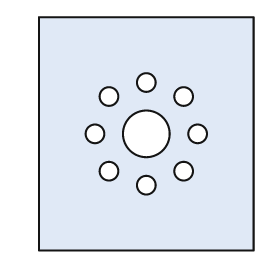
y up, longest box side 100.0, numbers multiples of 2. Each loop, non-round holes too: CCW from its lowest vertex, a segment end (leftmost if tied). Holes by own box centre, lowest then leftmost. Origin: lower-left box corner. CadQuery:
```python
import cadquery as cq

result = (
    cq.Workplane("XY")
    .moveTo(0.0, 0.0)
    .lineTo(92.0, 0.0)
    .lineTo(92.0, 100.0)
    .lineTo(0.0, 100.0)
    .close()
    .moveTo(46.0, 28.0)
    .circle(4.0)
    .moveTo(30.0, 34.0)
    .circle(4.0)
    .moveTo(62.0, 34.0)
    .circle(4.0)
    .moveTo(24.0, 50.0)
    .circle(4.0)
    .moveTo(46.0, 50.0)
    .circle(10.0)
    .moveTo(68.0, 50.0)
    .circle(4.0)
    .moveTo(30.0, 66.0)
    .circle(4.0)
    .moveTo(62.0, 66.0)
    .circle(4.0)
    .moveTo(46.0, 72.0)
    .circle(4.0)
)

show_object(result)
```